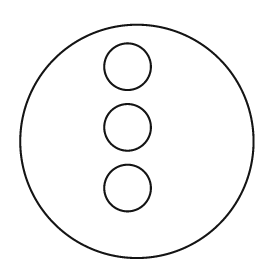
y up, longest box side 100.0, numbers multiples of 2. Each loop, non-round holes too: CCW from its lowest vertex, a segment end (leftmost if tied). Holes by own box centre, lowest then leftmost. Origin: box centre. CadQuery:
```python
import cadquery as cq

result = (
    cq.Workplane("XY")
    .moveTo(0.0, 0.0)
    .circle(50.0)
    .moveTo(-4.0, -20.0)
    .circle(10.0)
    .moveTo(-4.0, 6.0)
    .circle(10.0)
    .moveTo(-4.0, 32.0)
    .circle(10.0)
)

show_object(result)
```